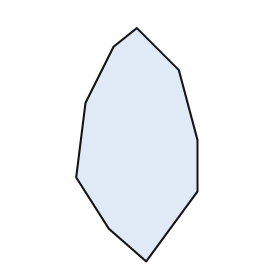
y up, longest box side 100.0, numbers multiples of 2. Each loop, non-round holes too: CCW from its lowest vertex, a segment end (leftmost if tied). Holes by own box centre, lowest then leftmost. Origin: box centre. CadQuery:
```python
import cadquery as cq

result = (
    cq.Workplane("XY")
    .moveTo(4.0, -50.0)
    .lineTo(26.0, -20.0)
    .lineTo(26.0, 2.0)
    .lineTo(18.0, 32.0)
    .lineTo(0.0, 50.0)
    .lineTo(-10.0, 42.0)
    .lineTo(-22.0, 18.0)
    .lineTo(-26.0, -14.0)
    .lineTo(-12.0, -36.0)
    .close()
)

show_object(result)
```